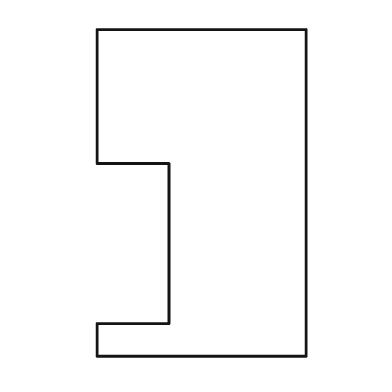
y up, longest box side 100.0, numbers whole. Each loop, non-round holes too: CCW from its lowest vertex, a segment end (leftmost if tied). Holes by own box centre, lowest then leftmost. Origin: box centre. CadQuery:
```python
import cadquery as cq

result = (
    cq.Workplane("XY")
    .moveTo(-32.0, -50.0)
    .lineTo(32.0, -50.0)
    .lineTo(32.0, 50.0)
    .lineTo(-32.0, 50.0)
    .lineTo(-32.0, 9.0)
    .lineTo(-10.0, 9.0)
    .lineTo(-10.0, -40.0)
    .lineTo(-32.0, -40.0)
    .close()
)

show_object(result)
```